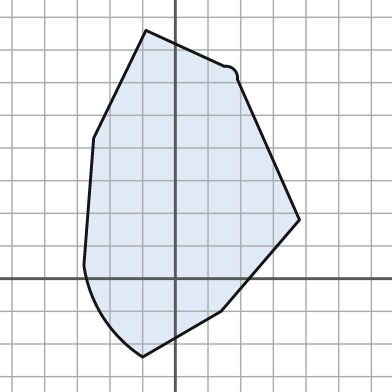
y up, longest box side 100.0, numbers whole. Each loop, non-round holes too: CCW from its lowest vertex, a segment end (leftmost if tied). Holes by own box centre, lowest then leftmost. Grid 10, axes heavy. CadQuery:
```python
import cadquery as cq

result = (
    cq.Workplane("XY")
    .moveTo(-10.0, -24.0)
    .lineTo(14.0, -10.0)
    .lineTo(38.0, 18.0)
    .lineTo(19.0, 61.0)
    .threePointArc((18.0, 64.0), (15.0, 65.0))
    .lineTo(-9.0, 76.0)
    .lineTo(-25.0, 43.0)
    .lineTo(-28.0, 4.0)
    .threePointArc((-22.0, -12.0), (-10.0, -24.0))
    .close()
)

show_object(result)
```